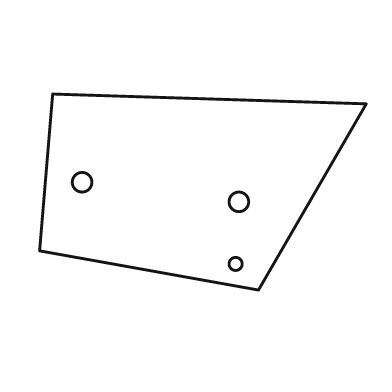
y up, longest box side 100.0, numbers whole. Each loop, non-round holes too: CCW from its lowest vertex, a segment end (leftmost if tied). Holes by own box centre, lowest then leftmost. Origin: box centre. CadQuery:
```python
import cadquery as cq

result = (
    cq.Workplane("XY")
    .moveTo(17.0, -30.0)
    .lineTo(50.0, 27.0)
    .lineTo(-46.0, 30.0)
    .lineTo(-50.0, -18.0)
    .close()
    .moveTo(10.0, -22.0)
    .circle(2.0)
    .moveTo(11.0, -3.0)
    .circle(3.0)
    .moveTo(-37.0, 3.0)
    .circle(3.0)
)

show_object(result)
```